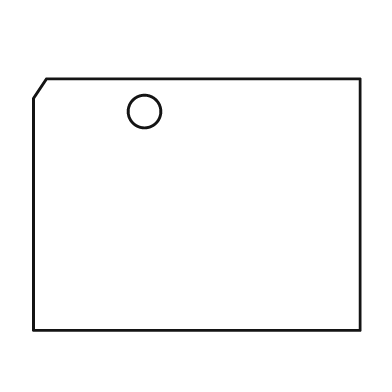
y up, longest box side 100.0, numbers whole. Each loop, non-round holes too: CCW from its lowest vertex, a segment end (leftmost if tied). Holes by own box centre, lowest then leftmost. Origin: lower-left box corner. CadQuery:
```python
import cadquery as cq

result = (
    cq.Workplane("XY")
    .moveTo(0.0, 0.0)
    .lineTo(100.0, 0.0)
    .lineTo(100.0, 77.0)
    .lineTo(4.0, 77.0)
    .lineTo(0.0, 71.0)
    .close()
    .moveTo(34.0, 67.0)
    .circle(5.0)
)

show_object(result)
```